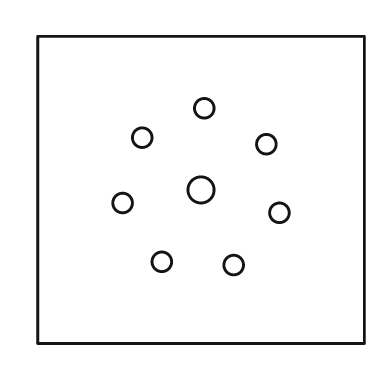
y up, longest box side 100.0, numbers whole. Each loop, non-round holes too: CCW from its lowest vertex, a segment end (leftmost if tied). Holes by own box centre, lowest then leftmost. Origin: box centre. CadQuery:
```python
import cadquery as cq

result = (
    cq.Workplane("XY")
    .moveTo(-50.0, -47.0)
    .lineTo(50.0, -47.0)
    .lineTo(50.0, 47.0)
    .lineTo(-50.0, 47.0)
    .close()
    .moveTo(10.0, -23.0)
    .circle(3.0)
    .moveTo(-12.0, -22.0)
    .circle(3.0)
    .moveTo(24.0, -7.0)
    .circle(3.0)
    .moveTo(-24.0, -4.0)
    .circle(3.0)
    .moveTo(0.0, 0.0)
    .circle(4.0)
    .moveTo(20.0, 14.0)
    .circle(3.0)
    .moveTo(-18.0, 16.0)
    .circle(3.0)
    .moveTo(1.0, 25.0)
    .circle(3.0)
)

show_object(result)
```